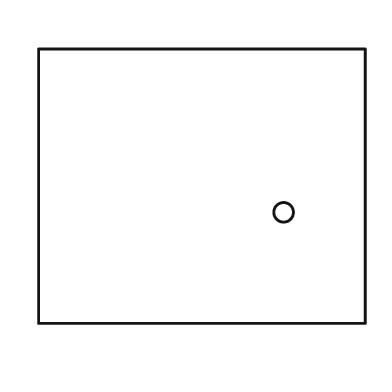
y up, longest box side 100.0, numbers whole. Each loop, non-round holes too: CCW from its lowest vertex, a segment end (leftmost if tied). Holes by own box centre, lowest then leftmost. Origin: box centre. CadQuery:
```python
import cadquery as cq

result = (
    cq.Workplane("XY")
    .moveTo(-50.0, -42.0)
    .lineTo(50.0, -42.0)
    .lineTo(50.0, 42.0)
    .lineTo(-50.0, 42.0)
    .close()
    .moveTo(25.0, -8.0)
    .circle(3.0)
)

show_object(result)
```